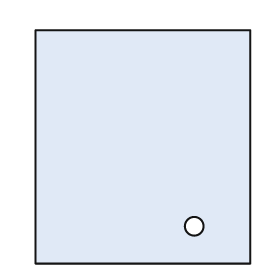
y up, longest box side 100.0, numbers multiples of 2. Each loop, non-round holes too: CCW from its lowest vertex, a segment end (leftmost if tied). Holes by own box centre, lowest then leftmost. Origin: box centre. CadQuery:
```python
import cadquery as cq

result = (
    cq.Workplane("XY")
    .moveTo(-46.0, -50.0)
    .lineTo(46.0, -50.0)
    .lineTo(46.0, 50.0)
    .lineTo(-46.0, 50.0)
    .close()
    .moveTo(22.0, -34.0)
    .circle(4.0)
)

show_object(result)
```